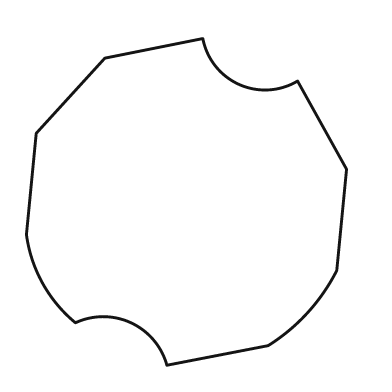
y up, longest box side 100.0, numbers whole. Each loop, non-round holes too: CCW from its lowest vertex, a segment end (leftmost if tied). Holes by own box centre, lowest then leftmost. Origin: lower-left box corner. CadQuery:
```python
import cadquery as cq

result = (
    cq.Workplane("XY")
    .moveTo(43.0, 0.0)
    .lineTo(74.0, 6.0)
    .threePointArc((86.0, 16.0), (95.0, 29.0))
    .lineTo(98.0, 60.0)
    .lineTo(83.0, 87.0)
    .threePointArc((65.0, 86.0), (54.0, 100.0))
    .lineTo(24.0, 94.0)
    .lineTo(3.0, 71.0)
    .lineTo(0.0, 40.0)
    .threePointArc((5.0, 25.0), (15.0, 13.0))
    .threePointArc((32.0, 13.0), (43.0, 0.0))
    .close()
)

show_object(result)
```